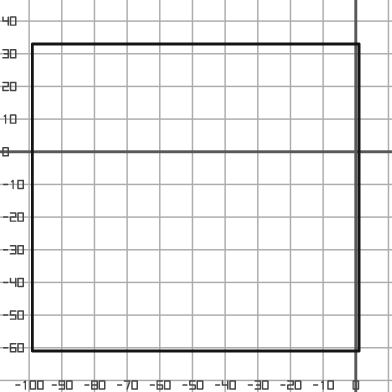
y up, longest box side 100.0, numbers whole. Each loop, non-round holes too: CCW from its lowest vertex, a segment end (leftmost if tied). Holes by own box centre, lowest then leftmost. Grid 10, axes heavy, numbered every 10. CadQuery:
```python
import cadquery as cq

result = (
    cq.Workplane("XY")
    .moveTo(-99.0, -61.0)
    .lineTo(1.0, -61.0)
    .lineTo(1.0, 33.0)
    .lineTo(-99.0, 33.0)
    .close()
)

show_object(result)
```